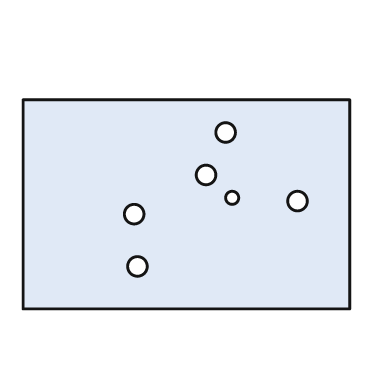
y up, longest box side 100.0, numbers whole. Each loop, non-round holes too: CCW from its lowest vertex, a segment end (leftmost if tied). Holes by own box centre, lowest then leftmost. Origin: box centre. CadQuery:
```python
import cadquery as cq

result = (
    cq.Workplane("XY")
    .moveTo(-50.0, -32.0)
    .lineTo(50.0, -32.0)
    .lineTo(50.0, 32.0)
    .lineTo(-50.0, 32.0)
    .close()
    .moveTo(-15.0, -19.0)
    .circle(3.0)
    .moveTo(-16.0, -3.0)
    .circle(3.0)
    .moveTo(34.0, 1.0)
    .circle(3.0)
    .moveTo(14.0, 2.0)
    .circle(2.0)
    .moveTo(6.0, 9.0)
    .circle(3.0)
    .moveTo(12.0, 22.0)
    .circle(3.0)
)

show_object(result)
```